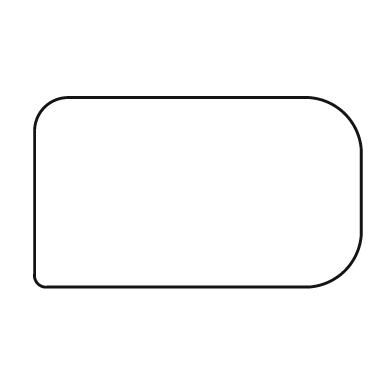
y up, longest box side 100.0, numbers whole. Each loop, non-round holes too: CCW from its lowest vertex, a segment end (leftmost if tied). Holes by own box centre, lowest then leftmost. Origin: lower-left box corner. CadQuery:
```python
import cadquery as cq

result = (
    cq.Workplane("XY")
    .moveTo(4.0, 0.0)
    .lineTo(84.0, 0.0)
    .threePointArc((95.0, 5.0), (100.0, 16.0))
    .lineTo(100.0, 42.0)
    .threePointArc((95.0, 53.0), (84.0, 58.0))
    .lineTo(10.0, 58.0)
    .threePointArc((3.0, 55.0), (0.0, 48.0))
    .lineTo(0.0, 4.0)
    .threePointArc((1.0, 1.0), (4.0, 0.0))
    .close()
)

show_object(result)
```